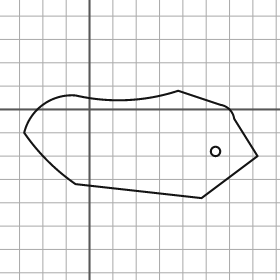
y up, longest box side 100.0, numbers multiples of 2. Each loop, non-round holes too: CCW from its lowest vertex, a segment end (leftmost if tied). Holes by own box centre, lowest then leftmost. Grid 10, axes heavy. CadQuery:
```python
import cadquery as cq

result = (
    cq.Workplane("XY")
    .moveTo(48.0, -38.0)
    .lineTo(72.0, -20.0)
    .lineTo(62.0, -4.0)
    .threePointArc((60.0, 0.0), (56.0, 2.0))
    .lineTo(38.0, 8.0)
    .threePointArc((16.0, 4.0), (-6.0, 6.0))
    .threePointArc((-20.0, 2.0), (-28.0, -10.0))
    .threePointArc((-18.0, -22.0), (-6.0, -32.0))
    .close()
    .moveTo(54.0, -18.0)
    .circle(2.0)
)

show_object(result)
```